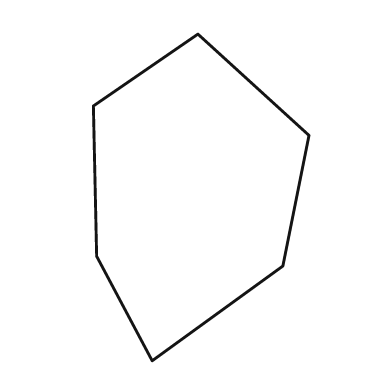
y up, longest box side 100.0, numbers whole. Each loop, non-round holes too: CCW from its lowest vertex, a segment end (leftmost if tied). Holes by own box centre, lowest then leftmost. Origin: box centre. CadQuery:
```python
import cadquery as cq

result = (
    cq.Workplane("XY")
    .moveTo(-15.0, -50.0)
    .lineTo(25.0, -21.0)
    .lineTo(33.0, 19.0)
    .lineTo(-1.0, 50.0)
    .lineTo(-33.0, 28.0)
    .lineTo(-32.0, -18.0)
    .close()
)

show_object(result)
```